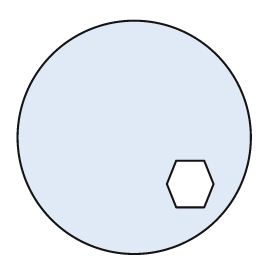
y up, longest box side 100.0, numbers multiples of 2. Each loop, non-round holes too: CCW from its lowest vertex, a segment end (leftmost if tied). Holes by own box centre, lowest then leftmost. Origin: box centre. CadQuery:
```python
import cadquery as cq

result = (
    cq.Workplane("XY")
    .moveTo(0.0, 0.0)
    .circle(50.0)
    .moveTo(18.0, -30.0)
    .lineTo(30.0, -30.0)
    .lineTo(34.0, -20.0)
    .lineTo(30.0, -10.0)
    .lineTo(18.0, -10.0)
    .lineTo(14.0, -20.0)
    .close()
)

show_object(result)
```